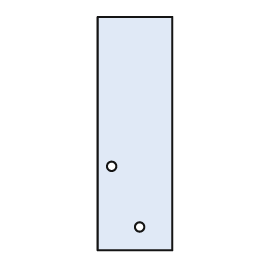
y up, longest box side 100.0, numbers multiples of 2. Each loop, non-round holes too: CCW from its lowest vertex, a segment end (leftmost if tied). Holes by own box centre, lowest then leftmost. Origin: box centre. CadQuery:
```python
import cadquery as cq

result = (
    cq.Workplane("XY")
    .moveTo(-16.0, -50.0)
    .lineTo(16.0, -50.0)
    .lineTo(16.0, 50.0)
    .lineTo(-16.0, 50.0)
    .close()
    .moveTo(2.0, -40.0)
    .circle(2.0)
    .moveTo(-10.0, -14.0)
    .circle(2.0)
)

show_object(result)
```